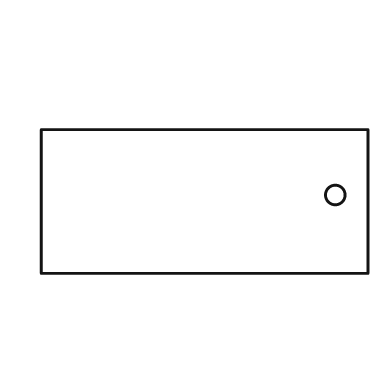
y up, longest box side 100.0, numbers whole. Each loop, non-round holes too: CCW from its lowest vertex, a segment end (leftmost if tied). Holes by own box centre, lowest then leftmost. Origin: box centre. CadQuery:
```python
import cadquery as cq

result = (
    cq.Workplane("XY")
    .moveTo(-50.0, -22.0)
    .lineTo(50.0, -22.0)
    .lineTo(50.0, 22.0)
    .lineTo(-50.0, 22.0)
    .close()
    .moveTo(40.0, 2.0)
    .circle(3.0)
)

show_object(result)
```